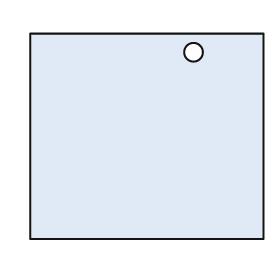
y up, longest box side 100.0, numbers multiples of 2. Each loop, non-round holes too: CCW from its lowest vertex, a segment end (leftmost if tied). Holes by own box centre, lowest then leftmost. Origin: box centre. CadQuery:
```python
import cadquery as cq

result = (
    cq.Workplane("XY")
    .moveTo(-50.0, -44.0)
    .lineTo(50.0, -44.0)
    .lineTo(50.0, 44.0)
    .lineTo(-50.0, 44.0)
    .close()
    .moveTo(20.0, 36.0)
    .circle(4.0)
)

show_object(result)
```